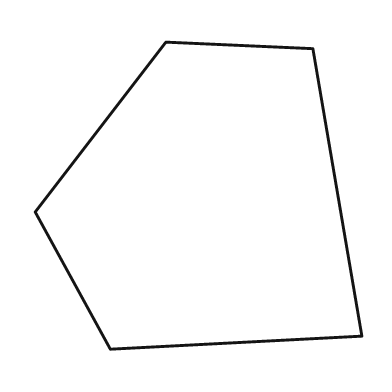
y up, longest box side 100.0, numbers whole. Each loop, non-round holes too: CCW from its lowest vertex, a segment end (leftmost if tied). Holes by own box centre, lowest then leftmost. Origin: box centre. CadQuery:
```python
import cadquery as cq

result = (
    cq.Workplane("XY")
    .moveTo(-27.0, -47.0)
    .lineTo(50.0, -43.0)
    .lineTo(35.0, 45.0)
    .lineTo(-10.0, 47.0)
    .lineTo(-50.0, -5.0)
    .close()
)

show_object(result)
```